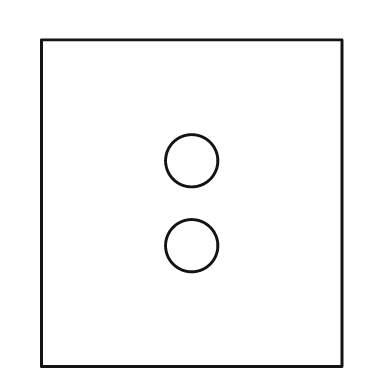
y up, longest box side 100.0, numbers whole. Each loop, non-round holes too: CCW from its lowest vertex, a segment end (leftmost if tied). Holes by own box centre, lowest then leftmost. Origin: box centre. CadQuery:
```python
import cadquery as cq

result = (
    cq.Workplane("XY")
    .moveTo(-46.0, -50.0)
    .lineTo(46.0, -50.0)
    .lineTo(46.0, 50.0)
    .lineTo(-46.0, 50.0)
    .close()
    .moveTo(0.0, -13.0)
    .circle(8.0)
    .moveTo(0.0, 13.0)
    .circle(8.0)
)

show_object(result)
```